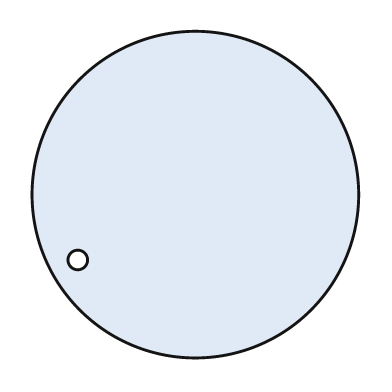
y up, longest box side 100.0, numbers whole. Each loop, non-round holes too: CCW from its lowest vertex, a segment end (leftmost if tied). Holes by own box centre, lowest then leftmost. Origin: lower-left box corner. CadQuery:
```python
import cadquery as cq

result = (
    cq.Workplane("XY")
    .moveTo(50.0, 50.0)
    .circle(50.0)
    .moveTo(14.0, 30.0)
    .circle(3.0)
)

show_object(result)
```